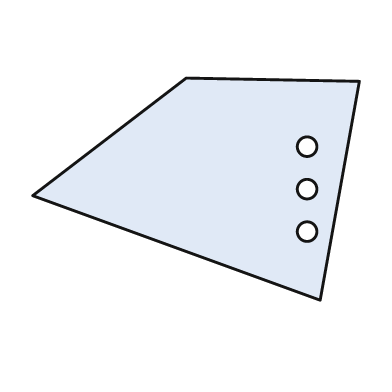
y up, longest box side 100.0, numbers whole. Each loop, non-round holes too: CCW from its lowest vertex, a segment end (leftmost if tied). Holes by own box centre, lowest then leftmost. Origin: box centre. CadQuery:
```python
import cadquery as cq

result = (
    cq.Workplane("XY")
    .moveTo(38.0, -34.0)
    .lineTo(50.0, 33.0)
    .lineTo(-3.0, 34.0)
    .lineTo(-50.0, -2.0)
    .close()
    .moveTo(34.0, -13.0)
    .circle(3.0)
    .moveTo(34.0, 0.0)
    .circle(3.0)
    .moveTo(34.0, 13.0)
    .circle(3.0)
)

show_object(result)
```